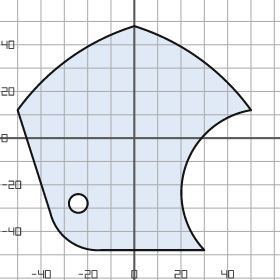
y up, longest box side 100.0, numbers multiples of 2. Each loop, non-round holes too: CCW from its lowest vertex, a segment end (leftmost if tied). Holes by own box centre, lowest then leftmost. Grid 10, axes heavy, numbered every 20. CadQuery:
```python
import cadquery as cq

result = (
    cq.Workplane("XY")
    .moveTo(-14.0, -48.0)
    .lineTo(30.0, -48.0)
    .threePointArc((22.0, -12.0), (50.0, 12.0))
    .threePointArc((28.0, 34.0), (0.0, 48.0))
    .threePointArc((-28.0, 34.0), (-50.0, 12.0))
    .lineTo(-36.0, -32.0)
    .threePointArc((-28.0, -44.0), (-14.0, -48.0))
    .close()
    .moveTo(-24.0, -28.0)
    .circle(4.0)
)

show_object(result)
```